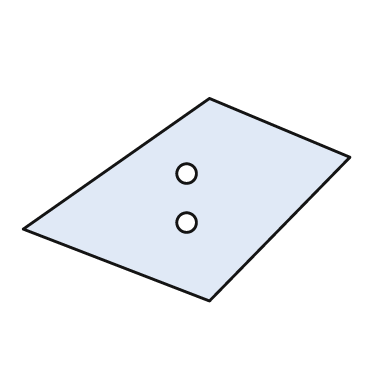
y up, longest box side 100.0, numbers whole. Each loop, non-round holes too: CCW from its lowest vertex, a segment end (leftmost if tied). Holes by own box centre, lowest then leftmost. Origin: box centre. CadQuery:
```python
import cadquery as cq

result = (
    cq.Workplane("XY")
    .moveTo(7.0, -31.0)
    .lineTo(50.0, 13.0)
    .lineTo(7.0, 31.0)
    .lineTo(-50.0, -9.0)
    .close()
    .moveTo(0.0, -7.0)
    .circle(3.0)
    .moveTo(0.0, 8.0)
    .circle(3.0)
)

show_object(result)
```